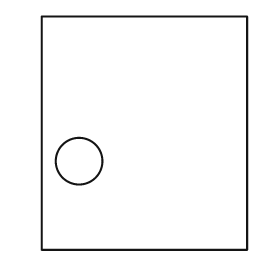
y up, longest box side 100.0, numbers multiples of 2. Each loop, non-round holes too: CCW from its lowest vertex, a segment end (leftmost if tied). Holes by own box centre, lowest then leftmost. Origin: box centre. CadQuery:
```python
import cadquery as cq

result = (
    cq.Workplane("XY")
    .moveTo(-44.0, -50.0)
    .lineTo(44.0, -50.0)
    .lineTo(44.0, 50.0)
    .lineTo(-44.0, 50.0)
    .close()
    .moveTo(-28.0, -12.0)
    .circle(10.0)
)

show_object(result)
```